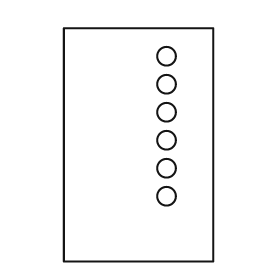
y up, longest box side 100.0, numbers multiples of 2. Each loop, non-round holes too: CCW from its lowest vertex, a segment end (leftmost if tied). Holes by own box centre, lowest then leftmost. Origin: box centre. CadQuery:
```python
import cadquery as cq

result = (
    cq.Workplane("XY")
    .moveTo(-32.0, -50.0)
    .lineTo(32.0, -50.0)
    .lineTo(32.0, 50.0)
    .lineTo(-32.0, 50.0)
    .close()
    .moveTo(12.0, -22.0)
    .circle(4.0)
    .moveTo(12.0, -10.0)
    .circle(4.0)
    .moveTo(12.0, 2.0)
    .circle(4.0)
    .moveTo(12.0, 14.0)
    .circle(4.0)
    .moveTo(12.0, 26.0)
    .circle(4.0)
    .moveTo(12.0, 38.0)
    .circle(4.0)
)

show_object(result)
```